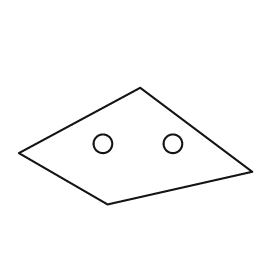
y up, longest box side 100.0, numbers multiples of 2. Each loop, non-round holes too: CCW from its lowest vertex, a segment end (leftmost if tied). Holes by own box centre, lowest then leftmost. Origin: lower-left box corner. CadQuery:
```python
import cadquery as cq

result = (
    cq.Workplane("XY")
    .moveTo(38.0, 0.0)
    .lineTo(100.0, 14.0)
    .lineTo(52.0, 50.0)
    .lineTo(0.0, 22.0)
    .close()
    .moveTo(36.0, 26.0)
    .circle(4.0)
    .moveTo(66.0, 26.0)
    .circle(4.0)
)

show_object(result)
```